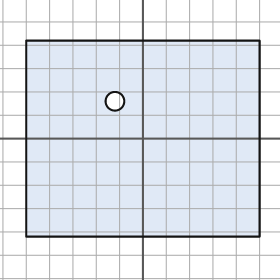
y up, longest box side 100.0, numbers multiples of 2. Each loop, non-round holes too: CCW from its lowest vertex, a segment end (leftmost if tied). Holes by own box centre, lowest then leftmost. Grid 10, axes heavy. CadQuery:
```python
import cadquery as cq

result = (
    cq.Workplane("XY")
    .moveTo(-50.0, -42.0)
    .lineTo(50.0, -42.0)
    .lineTo(50.0, 42.0)
    .lineTo(-50.0, 42.0)
    .close()
    .moveTo(-12.0, 16.0)
    .circle(4.0)
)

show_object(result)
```